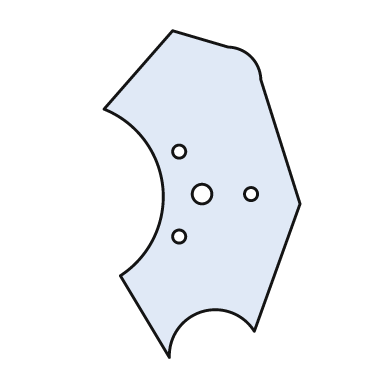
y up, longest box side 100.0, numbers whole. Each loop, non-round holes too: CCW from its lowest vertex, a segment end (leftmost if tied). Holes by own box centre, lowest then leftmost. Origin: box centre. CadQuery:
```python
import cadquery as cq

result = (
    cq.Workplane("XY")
    .moveTo(-10.0, -50.0)
    .threePointArc((0.0, -36.0), (16.0, -42.0))
    .lineTo(30.0, -3.0)
    .lineTo(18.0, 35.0)
    .threePointArc((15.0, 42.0), (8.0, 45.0))
    .lineTo(-9.0, 50.0)
    .lineTo(-30.0, 26.0)
    .threePointArc((-12.0, 2.0), (-25.0, -25.0))
    .close()
    .moveTo(-7.0, -13.0)
    .circle(2.0)
    .moveTo(0.0, 0.0)
    .circle(3.0)
    .moveTo(15.0, 0.0)
    .circle(2.0)
    .moveTo(-7.0, 13.0)
    .circle(2.0)
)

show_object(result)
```